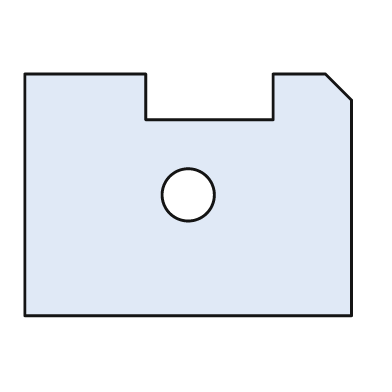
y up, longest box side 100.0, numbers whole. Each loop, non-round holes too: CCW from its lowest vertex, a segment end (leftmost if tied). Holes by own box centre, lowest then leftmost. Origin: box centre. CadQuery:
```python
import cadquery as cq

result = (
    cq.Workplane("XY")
    .moveTo(-50.0, -37.0)
    .lineTo(50.0, -37.0)
    .lineTo(50.0, 29.0)
    .lineTo(42.0, 37.0)
    .lineTo(26.0, 37.0)
    .lineTo(26.0, 23.0)
    .lineTo(-13.0, 23.0)
    .lineTo(-13.0, 37.0)
    .lineTo(-50.0, 37.0)
    .close()
    .moveTo(0.0, 0.0)
    .circle(8.0)
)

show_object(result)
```